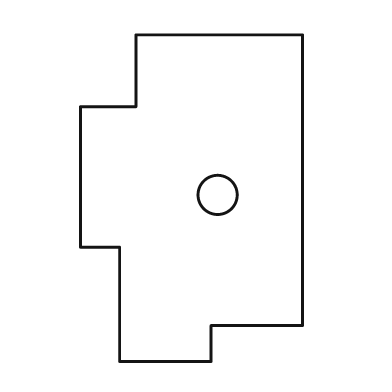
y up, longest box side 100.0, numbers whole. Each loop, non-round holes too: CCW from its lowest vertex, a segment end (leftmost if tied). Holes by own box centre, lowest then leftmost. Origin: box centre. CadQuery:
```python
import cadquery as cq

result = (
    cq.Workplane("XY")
    .moveTo(-22.0, -50.0)
    .lineTo(6.0, -50.0)
    .lineTo(6.0, -39.0)
    .lineTo(34.0, -39.0)
    .lineTo(34.0, 50.0)
    .lineTo(-17.0, 50.0)
    .lineTo(-17.0, 28.0)
    .lineTo(-34.0, 28.0)
    .lineTo(-34.0, -15.0)
    .lineTo(-22.0, -15.0)
    .close()
    .moveTo(8.0, 1.0)
    .circle(6.0)
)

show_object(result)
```